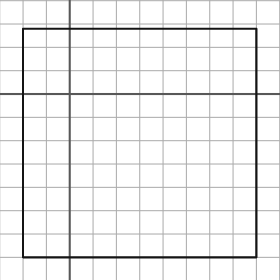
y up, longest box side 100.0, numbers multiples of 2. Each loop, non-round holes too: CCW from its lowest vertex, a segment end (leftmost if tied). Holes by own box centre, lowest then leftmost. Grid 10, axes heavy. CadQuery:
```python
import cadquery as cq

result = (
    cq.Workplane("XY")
    .moveTo(-20.0, -70.0)
    .lineTo(80.0, -70.0)
    .lineTo(80.0, 28.0)
    .lineTo(-20.0, 28.0)
    .close()
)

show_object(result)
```